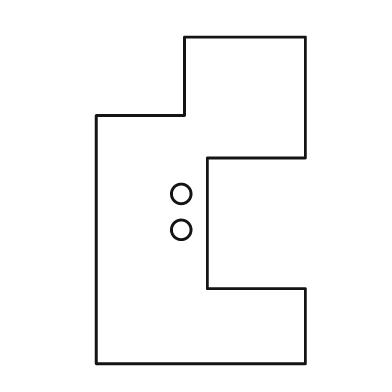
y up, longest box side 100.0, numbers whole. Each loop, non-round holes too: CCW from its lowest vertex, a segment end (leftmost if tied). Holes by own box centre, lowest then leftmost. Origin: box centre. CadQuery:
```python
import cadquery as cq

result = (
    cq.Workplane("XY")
    .moveTo(-32.0, -50.0)
    .lineTo(32.0, -50.0)
    .lineTo(32.0, -27.0)
    .lineTo(2.0, -27.0)
    .lineTo(2.0, 13.0)
    .lineTo(32.0, 13.0)
    .lineTo(32.0, 50.0)
    .lineTo(-5.0, 50.0)
    .lineTo(-5.0, 26.0)
    .lineTo(-32.0, 26.0)
    .close()
    .moveTo(-6.0, -9.0)
    .circle(3.0)
    .moveTo(-6.0, 2.0)
    .circle(3.0)
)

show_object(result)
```